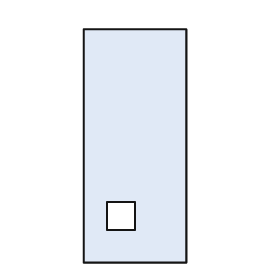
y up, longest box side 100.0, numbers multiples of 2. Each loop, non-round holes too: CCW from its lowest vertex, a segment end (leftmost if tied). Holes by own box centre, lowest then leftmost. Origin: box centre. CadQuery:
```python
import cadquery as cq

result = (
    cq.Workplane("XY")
    .moveTo(-22.0, -50.0)
    .lineTo(22.0, -50.0)
    .lineTo(22.0, 50.0)
    .lineTo(-22.0, 50.0)
    .close()
    .moveTo(-12.0, -36.0)
    .lineTo(0.0, -36.0)
    .lineTo(0.0, -24.0)
    .lineTo(-12.0, -24.0)
    .close()
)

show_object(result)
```